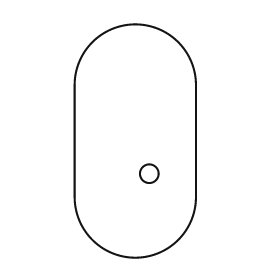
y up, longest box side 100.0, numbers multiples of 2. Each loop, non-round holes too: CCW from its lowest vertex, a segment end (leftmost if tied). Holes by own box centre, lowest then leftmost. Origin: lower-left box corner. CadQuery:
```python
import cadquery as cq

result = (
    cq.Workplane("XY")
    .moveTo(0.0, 26.0)
    .threePointArc((26.0, 0.0), (52.0, 26.0))
    .lineTo(52.0, 74.0)
    .threePointArc((26.0, 100.0), (0.0, 74.0))
    .close()
    .moveTo(32.0, 36.0)
    .circle(4.0)
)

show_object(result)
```